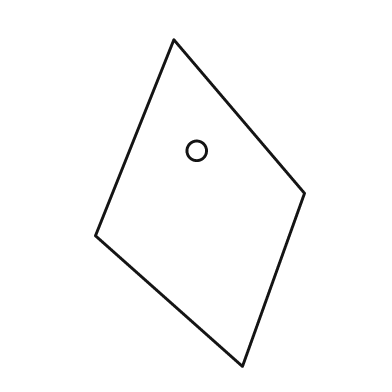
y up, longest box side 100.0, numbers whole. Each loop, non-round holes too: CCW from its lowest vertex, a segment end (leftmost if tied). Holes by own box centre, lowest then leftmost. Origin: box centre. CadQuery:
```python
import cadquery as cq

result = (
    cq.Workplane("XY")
    .moveTo(13.0, -50.0)
    .lineTo(32.0, 3.0)
    .lineTo(-8.0, 50.0)
    .lineTo(-32.0, -10.0)
    .close()
    .moveTo(-1.0, 16.0)
    .circle(3.0)
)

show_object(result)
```